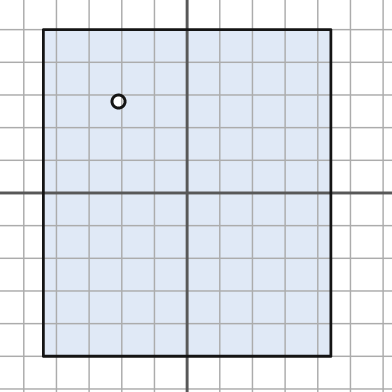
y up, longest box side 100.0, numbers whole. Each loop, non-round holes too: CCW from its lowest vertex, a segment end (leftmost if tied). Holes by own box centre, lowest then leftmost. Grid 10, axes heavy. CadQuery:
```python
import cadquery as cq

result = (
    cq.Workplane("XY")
    .moveTo(-44.0, -50.0)
    .lineTo(44.0, -50.0)
    .lineTo(44.0, 50.0)
    .lineTo(-44.0, 50.0)
    .close()
    .moveTo(-21.0, 28.0)
    .circle(2.0)
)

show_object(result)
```